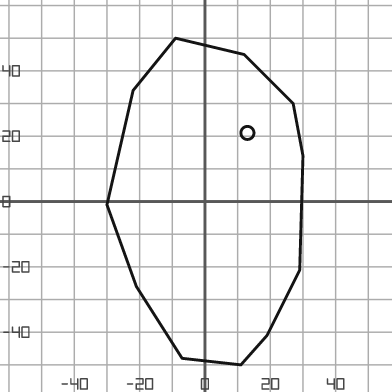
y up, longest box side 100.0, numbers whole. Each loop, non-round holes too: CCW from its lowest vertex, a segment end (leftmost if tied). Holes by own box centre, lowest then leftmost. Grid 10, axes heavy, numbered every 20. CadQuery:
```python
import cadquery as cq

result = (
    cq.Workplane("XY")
    .moveTo(11.0, -50.0)
    .lineTo(19.0, -41.0)
    .lineTo(29.0, -21.0)
    .lineTo(30.0, 14.0)
    .lineTo(27.0, 30.0)
    .lineTo(12.0, 45.0)
    .lineTo(-9.0, 50.0)
    .lineTo(-22.0, 34.0)
    .lineTo(-30.0, -1.0)
    .lineTo(-21.0, -26.0)
    .lineTo(-7.0, -48.0)
    .close()
    .moveTo(13.0, 21.0)
    .circle(2.0)
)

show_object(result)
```